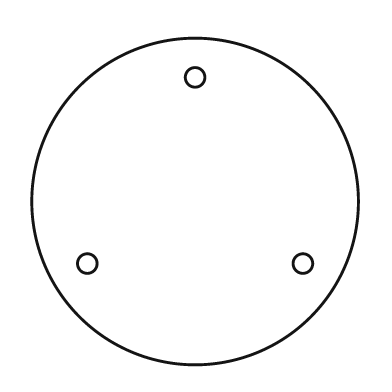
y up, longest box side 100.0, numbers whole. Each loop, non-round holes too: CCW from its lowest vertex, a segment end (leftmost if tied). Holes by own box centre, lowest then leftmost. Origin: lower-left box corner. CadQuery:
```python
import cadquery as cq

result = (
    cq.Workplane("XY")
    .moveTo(50.0, 50.0)
    .circle(50.0)
    .moveTo(17.0, 31.0)
    .circle(3.0)
    .moveTo(83.0, 31.0)
    .circle(3.0)
    .moveTo(50.0, 88.0)
    .circle(3.0)
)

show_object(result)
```